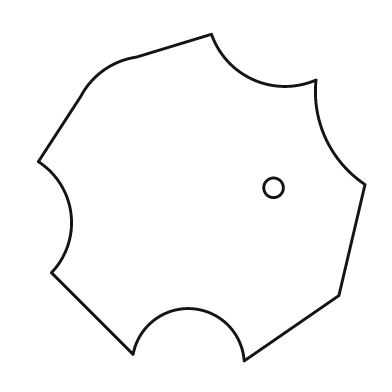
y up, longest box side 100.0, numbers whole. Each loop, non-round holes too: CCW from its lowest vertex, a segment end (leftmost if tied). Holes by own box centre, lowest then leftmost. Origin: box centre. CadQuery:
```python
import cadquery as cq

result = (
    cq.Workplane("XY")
    .moveTo(13.0, -50.0)
    .lineTo(42.0, -30.0)
    .lineTo(50.0, 4.0)
    .threePointArc((38.0, 18.0), (35.0, 36.0))
    .threePointArc((16.0, 36.0), (3.0, 50.0))
    .lineTo(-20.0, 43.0)
    .threePointArc((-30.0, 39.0), (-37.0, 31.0))
    .lineTo(-50.0, 11.0)
    .threePointArc((-40.0, -5.0), (-46.0, -23.0))
    .lineTo(-21.0, -48.0)
    .threePointArc((-3.0, -34.0), (13.0, -50.0))
    .close()
    .moveTo(22.0, 3.0)
    .circle(3.0)
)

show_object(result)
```